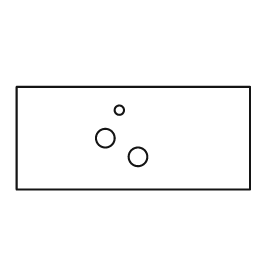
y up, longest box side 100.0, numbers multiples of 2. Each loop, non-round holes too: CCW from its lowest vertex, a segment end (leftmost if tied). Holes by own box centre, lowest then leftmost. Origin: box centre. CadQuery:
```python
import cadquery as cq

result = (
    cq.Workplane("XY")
    .moveTo(-50.0, -22.0)
    .lineTo(50.0, -22.0)
    .lineTo(50.0, 22.0)
    .lineTo(-50.0, 22.0)
    .close()
    .moveTo(2.0, -8.0)
    .circle(4.0)
    .moveTo(-12.0, 0.0)
    .circle(4.0)
    .moveTo(-6.0, 12.0)
    .circle(2.0)
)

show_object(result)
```